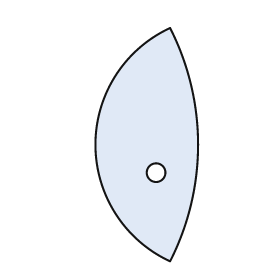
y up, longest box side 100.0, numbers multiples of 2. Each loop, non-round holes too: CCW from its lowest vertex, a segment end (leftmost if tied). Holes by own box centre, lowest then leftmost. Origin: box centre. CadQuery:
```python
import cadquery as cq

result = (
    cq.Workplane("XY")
    .moveTo(10.0, -50.0)
    .threePointArc((22.0, 0.0), (10.0, 50.0))
    .threePointArc((-22.0, 0.0), (10.0, -50.0))
    .close()
    .moveTo(4.0, -12.0)
    .circle(4.0)
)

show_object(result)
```